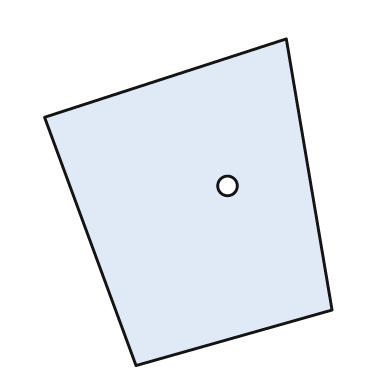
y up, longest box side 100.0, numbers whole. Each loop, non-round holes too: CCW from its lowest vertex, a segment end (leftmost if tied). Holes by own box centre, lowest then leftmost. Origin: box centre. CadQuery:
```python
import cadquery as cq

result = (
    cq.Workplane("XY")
    .moveTo(-16.0, -50.0)
    .lineTo(44.0, -33.0)
    .lineTo(30.0, 50.0)
    .lineTo(-44.0, 26.0)
    .close()
    .moveTo(12.0, 5.0)
    .circle(3.0)
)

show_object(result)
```